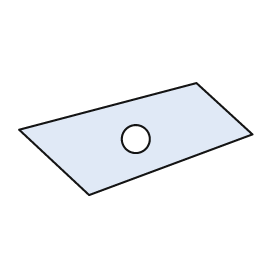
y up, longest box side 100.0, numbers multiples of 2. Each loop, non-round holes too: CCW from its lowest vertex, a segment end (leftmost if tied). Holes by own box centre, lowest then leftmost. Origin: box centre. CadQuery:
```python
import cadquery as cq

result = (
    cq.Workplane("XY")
    .moveTo(-20.0, -24.0)
    .lineTo(50.0, 2.0)
    .lineTo(26.0, 24.0)
    .lineTo(-50.0, 4.0)
    .close()
    .moveTo(0.0, 0.0)
    .circle(6.0)
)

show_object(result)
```